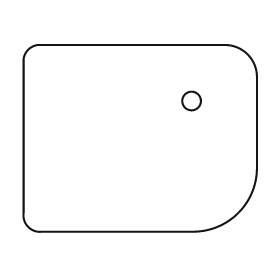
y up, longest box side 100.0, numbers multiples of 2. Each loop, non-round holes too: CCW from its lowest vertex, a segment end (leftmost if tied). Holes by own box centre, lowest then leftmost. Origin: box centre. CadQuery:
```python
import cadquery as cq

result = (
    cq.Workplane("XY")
    .moveTo(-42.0, -40.0)
    .lineTo(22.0, -40.0)
    .threePointArc((42.0, -32.0), (50.0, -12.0))
    .lineTo(50.0, 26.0)
    .threePointArc((46.0, 36.0), (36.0, 40.0))
    .lineTo(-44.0, 40.0)
    .threePointArc((-48.0, 38.0), (-50.0, 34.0))
    .lineTo(-50.0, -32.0)
    .threePointArc((-48.0, -38.0), (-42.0, -40.0))
    .close()
    .moveTo(22.0, 16.0)
    .circle(4.0)
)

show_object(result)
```